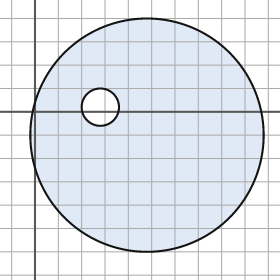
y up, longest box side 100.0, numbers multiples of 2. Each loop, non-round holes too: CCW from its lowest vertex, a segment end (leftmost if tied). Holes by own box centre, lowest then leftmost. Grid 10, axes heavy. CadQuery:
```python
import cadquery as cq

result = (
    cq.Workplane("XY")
    .moveTo(48.0, -10.0)
    .circle(50.0)
    .moveTo(28.0, 2.0)
    .circle(8.0)
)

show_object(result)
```